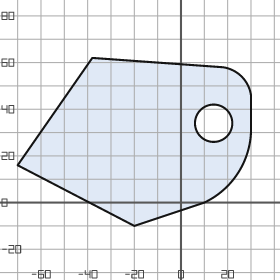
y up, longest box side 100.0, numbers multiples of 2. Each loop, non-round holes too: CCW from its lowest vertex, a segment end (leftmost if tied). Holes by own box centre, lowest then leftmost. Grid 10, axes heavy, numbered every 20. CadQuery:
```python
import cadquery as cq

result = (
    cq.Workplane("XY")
    .moveTo(-20.0, -10.0)
    .lineTo(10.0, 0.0)
    .threePointArc((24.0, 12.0), (30.0, 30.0))
    .lineTo(30.0, 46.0)
    .threePointArc((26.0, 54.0), (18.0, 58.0))
    .lineTo(-38.0, 62.0)
    .lineTo(-70.0, 16.0)
    .close()
    .moveTo(14.0, 34.0)
    .circle(8.0)
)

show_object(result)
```